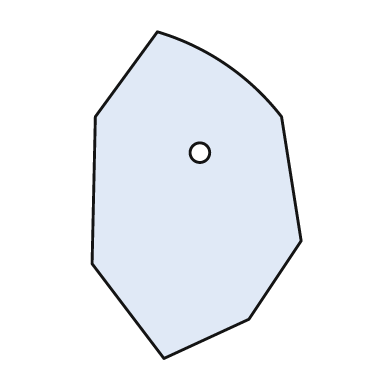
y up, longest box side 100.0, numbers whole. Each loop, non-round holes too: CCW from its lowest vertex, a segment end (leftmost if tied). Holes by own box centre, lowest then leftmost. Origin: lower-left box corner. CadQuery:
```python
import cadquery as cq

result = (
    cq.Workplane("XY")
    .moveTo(22.0, 0.0)
    .lineTo(48.0, 12.0)
    .lineTo(64.0, 36.0)
    .lineTo(58.0, 74.0)
    .threePointArc((41.0, 90.0), (20.0, 100.0))
    .lineTo(1.0, 74.0)
    .lineTo(0.0, 29.0)
    .close()
    .moveTo(33.0, 63.0)
    .circle(3.0)
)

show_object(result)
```